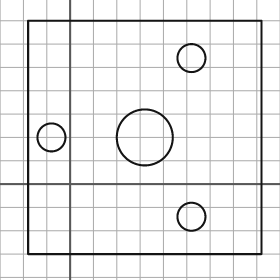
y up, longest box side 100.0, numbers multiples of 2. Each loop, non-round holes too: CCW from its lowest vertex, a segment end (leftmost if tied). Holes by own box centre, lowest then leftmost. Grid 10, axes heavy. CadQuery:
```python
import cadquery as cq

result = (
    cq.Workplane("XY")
    .moveTo(-18.0, -30.0)
    .lineTo(82.0, -30.0)
    .lineTo(82.0, 70.0)
    .lineTo(-18.0, 70.0)
    .close()
    .moveTo(52.0, -14.0)
    .circle(6.0)
    .moveTo(-8.0, 20.0)
    .circle(6.0)
    .moveTo(32.0, 20.0)
    .circle(12.0)
    .moveTo(52.0, 54.0)
    .circle(6.0)
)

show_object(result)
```